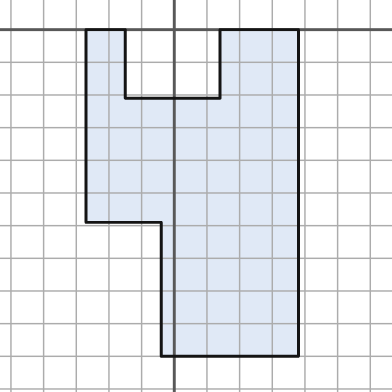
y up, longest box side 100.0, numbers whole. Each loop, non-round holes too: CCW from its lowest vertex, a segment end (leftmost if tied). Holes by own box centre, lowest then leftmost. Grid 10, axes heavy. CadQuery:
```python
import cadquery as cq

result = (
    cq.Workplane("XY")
    .moveTo(-4.0, -100.0)
    .lineTo(38.0, -100.0)
    .lineTo(38.0, 0.0)
    .lineTo(14.0, 0.0)
    .lineTo(14.0, -21.0)
    .lineTo(-15.0, -21.0)
    .lineTo(-15.0, 0.0)
    .lineTo(-27.0, 0.0)
    .lineTo(-27.0, -59.0)
    .lineTo(-4.0, -59.0)
    .close()
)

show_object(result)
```